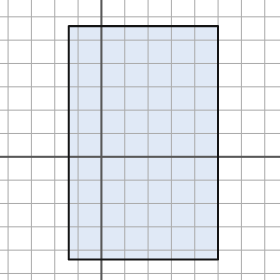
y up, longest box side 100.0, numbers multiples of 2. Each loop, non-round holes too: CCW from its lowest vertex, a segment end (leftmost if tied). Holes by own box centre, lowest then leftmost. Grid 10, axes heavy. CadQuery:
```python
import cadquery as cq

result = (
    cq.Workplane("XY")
    .moveTo(-14.0, -44.0)
    .lineTo(50.0, -44.0)
    .lineTo(50.0, 56.0)
    .lineTo(-14.0, 56.0)
    .close()
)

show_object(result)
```